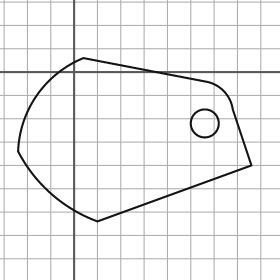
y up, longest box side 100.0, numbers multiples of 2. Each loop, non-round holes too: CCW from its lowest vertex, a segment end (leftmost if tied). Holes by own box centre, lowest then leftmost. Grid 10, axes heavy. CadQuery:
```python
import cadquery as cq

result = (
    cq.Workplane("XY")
    .moveTo(10.0, -64.0)
    .lineTo(76.0, -40.0)
    .lineTo(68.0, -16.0)
    .threePointArc((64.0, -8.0), (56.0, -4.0))
    .lineTo(4.0, 6.0)
    .threePointArc((-16.0, -10.0), (-24.0, -34.0))
    .threePointArc((-10.0, -52.0), (10.0, -64.0))
    .close()
    .moveTo(56.0, -22.0)
    .circle(6.0)
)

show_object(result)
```